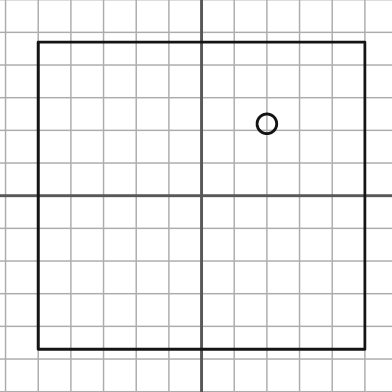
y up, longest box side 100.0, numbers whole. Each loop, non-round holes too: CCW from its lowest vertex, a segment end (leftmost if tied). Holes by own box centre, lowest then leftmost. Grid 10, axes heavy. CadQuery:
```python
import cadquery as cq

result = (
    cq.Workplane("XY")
    .moveTo(-50.0, -47.0)
    .lineTo(50.0, -47.0)
    .lineTo(50.0, 47.0)
    .lineTo(-50.0, 47.0)
    .close()
    .moveTo(20.0, 22.0)
    .circle(3.0)
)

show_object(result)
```